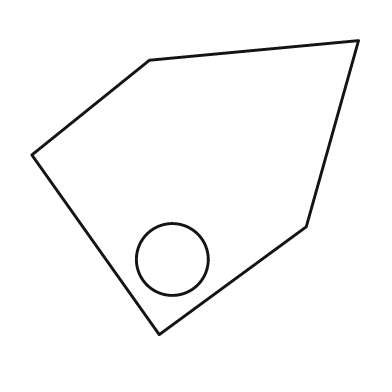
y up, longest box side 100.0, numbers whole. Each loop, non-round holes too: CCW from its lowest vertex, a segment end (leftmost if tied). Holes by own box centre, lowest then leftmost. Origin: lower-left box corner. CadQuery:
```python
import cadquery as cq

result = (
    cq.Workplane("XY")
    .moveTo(39.0, 0.0)
    .lineTo(84.0, 33.0)
    .lineTo(100.0, 90.0)
    .lineTo(36.0, 84.0)
    .lineTo(0.0, 55.0)
    .close()
    .moveTo(43.0, 23.0)
    .circle(11.0)
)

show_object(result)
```